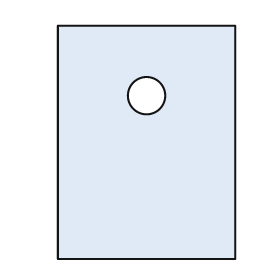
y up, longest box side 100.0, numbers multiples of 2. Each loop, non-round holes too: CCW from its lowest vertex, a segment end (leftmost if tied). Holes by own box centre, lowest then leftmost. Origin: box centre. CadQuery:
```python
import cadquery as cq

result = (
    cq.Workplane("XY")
    .moveTo(-38.0, -50.0)
    .lineTo(38.0, -50.0)
    .lineTo(38.0, 50.0)
    .lineTo(-38.0, 50.0)
    .close()
    .moveTo(0.0, 20.0)
    .circle(8.0)
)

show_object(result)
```